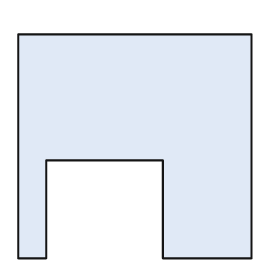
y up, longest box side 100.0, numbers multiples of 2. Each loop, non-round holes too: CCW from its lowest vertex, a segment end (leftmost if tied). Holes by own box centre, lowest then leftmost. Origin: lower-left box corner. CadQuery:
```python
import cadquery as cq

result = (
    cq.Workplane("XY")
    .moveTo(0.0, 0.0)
    .lineTo(12.0, 0.0)
    .lineTo(12.0, 42.0)
    .lineTo(62.0, 42.0)
    .lineTo(62.0, 0.0)
    .lineTo(100.0, 0.0)
    .lineTo(100.0, 96.0)
    .lineTo(0.0, 96.0)
    .close()
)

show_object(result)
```